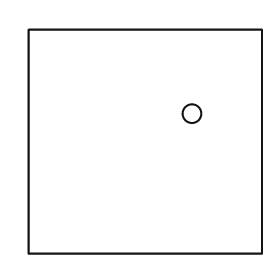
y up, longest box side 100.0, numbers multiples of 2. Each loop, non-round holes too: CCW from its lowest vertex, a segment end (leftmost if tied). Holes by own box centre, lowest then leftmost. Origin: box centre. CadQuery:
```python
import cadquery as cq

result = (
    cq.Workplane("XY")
    .moveTo(-50.0, -48.0)
    .lineTo(50.0, -48.0)
    .lineTo(50.0, 48.0)
    .lineTo(-50.0, 48.0)
    .close()
    .moveTo(20.0, 12.0)
    .circle(4.0)
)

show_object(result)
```